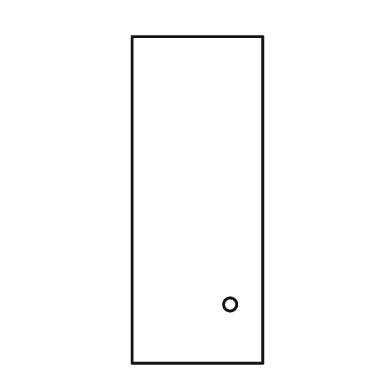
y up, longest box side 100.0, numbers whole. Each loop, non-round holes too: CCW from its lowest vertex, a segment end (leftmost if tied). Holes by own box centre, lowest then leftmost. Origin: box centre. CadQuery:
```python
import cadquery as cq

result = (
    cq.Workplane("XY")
    .moveTo(-20.0, -50.0)
    .lineTo(20.0, -50.0)
    .lineTo(20.0, 50.0)
    .lineTo(-20.0, 50.0)
    .close()
    .moveTo(10.0, -32.0)
    .circle(2.0)
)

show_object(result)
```